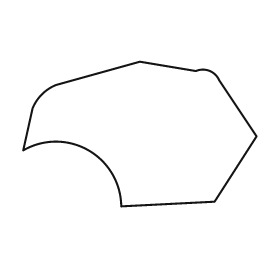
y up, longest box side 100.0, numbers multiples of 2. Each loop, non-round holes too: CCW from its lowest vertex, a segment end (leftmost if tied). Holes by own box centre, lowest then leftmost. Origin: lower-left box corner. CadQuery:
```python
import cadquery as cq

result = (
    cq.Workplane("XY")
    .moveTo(42.0, 0.0)
    .lineTo(82.0, 2.0)
    .lineTo(100.0, 30.0)
    .lineTo(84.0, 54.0)
    .threePointArc((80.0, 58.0), (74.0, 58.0))
    .lineTo(50.0, 62.0)
    .lineTo(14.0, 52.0)
    .threePointArc((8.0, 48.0), (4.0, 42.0))
    .lineTo(0.0, 24.0)
    .threePointArc((28.0, 24.0), (42.0, 0.0))
    .close()
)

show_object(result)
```